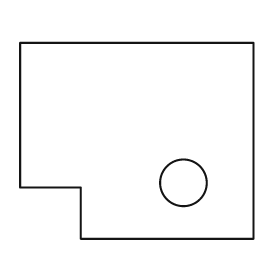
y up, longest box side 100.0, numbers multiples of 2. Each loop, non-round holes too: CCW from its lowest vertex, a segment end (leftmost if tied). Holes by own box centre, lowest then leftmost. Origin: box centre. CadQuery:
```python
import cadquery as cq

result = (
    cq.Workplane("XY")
    .moveTo(-24.0, -42.0)
    .lineTo(50.0, -42.0)
    .lineTo(50.0, 42.0)
    .lineTo(-50.0, 42.0)
    .lineTo(-50.0, -20.0)
    .lineTo(-24.0, -20.0)
    .close()
    .moveTo(20.0, -18.0)
    .circle(10.0)
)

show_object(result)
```